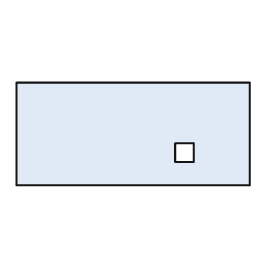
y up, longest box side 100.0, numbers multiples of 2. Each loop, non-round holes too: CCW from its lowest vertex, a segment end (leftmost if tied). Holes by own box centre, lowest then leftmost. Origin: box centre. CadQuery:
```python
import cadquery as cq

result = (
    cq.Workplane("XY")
    .moveTo(-50.0, -22.0)
    .lineTo(50.0, -22.0)
    .lineTo(50.0, 22.0)
    .lineTo(-50.0, 22.0)
    .close()
    .moveTo(18.0, -12.0)
    .lineTo(26.0, -12.0)
    .lineTo(26.0, -4.0)
    .lineTo(18.0, -4.0)
    .close()
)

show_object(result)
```